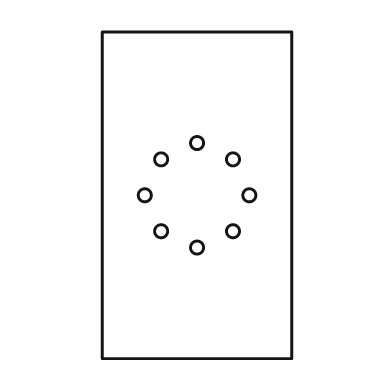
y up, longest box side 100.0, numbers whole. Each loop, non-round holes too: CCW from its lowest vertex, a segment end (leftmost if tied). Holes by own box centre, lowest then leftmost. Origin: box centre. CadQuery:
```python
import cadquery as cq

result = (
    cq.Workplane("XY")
    .moveTo(-29.0, -50.0)
    .lineTo(29.0, -50.0)
    .lineTo(29.0, 50.0)
    .lineTo(-29.0, 50.0)
    .close()
    .moveTo(0.0, -16.0)
    .circle(2.0)
    .moveTo(-11.0, -11.0)
    .circle(2.0)
    .moveTo(11.0, -11.0)
    .circle(2.0)
    .moveTo(-16.0, 0.0)
    .circle(2.0)
    .moveTo(16.0, 0.0)
    .circle(2.0)
    .moveTo(-11.0, 11.0)
    .circle(2.0)
    .moveTo(11.0, 11.0)
    .circle(2.0)
    .moveTo(0.0, 16.0)
    .circle(2.0)
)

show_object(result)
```